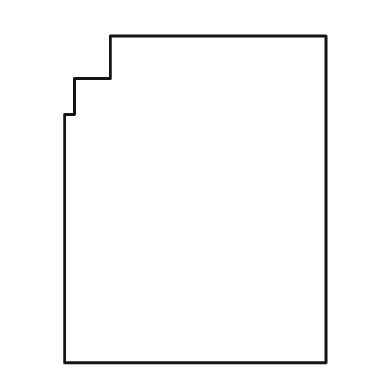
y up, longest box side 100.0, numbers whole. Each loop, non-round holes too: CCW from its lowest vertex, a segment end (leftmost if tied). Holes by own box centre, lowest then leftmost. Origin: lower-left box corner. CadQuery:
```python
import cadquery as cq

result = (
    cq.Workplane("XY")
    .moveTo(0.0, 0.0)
    .lineTo(80.0, 0.0)
    .lineTo(80.0, 100.0)
    .lineTo(14.0, 100.0)
    .lineTo(14.0, 87.0)
    .lineTo(3.0, 87.0)
    .lineTo(3.0, 76.0)
    .lineTo(0.0, 76.0)
    .close()
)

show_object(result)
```